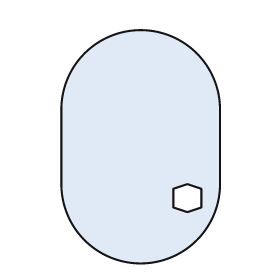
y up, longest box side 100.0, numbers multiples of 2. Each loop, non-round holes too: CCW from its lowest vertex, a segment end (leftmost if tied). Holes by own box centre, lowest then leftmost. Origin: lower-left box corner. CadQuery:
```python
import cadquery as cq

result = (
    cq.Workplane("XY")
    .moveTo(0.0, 34.0)
    .threePointArc((34.0, 0.0), (68.0, 34.0))
    .lineTo(68.0, 66.0)
    .threePointArc((34.0, 100.0), (0.0, 66.0))
    .close()
    .moveTo(54.0, 22.0)
    .lineTo(60.0, 24.0)
    .lineTo(60.0, 32.0)
    .lineTo(54.0, 34.0)
    .lineTo(48.0, 32.0)
    .lineTo(48.0, 24.0)
    .close()
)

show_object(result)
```